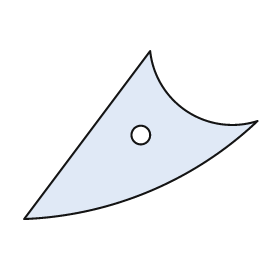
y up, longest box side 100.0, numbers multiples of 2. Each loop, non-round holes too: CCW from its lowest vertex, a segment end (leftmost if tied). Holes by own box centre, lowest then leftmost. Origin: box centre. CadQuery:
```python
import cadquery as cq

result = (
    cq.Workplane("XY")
    .moveTo(-50.0, -36.0)
    .threePointArc((4.0, -24.0), (50.0, 6.0))
    .threePointArc((20.0, 10.0), (4.0, 36.0))
    .close()
    .moveTo(0.0, 0.0)
    .circle(4.0)
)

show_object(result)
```